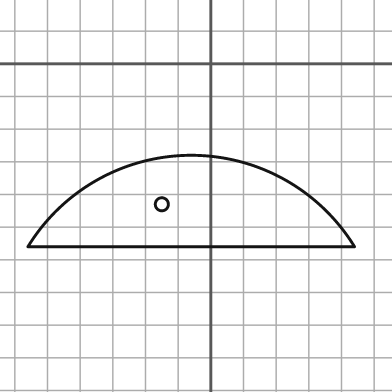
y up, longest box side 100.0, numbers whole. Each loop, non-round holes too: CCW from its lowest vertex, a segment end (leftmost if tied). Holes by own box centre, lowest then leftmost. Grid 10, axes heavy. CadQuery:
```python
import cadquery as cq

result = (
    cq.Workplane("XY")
    .moveTo(-56.0, -56.0)
    .lineTo(44.0, -56.0)
    .threePointArc((-6.0, -28.0), (-56.0, -56.0))
    .close()
    .moveTo(-15.0, -43.0)
    .circle(2.0)
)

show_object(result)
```